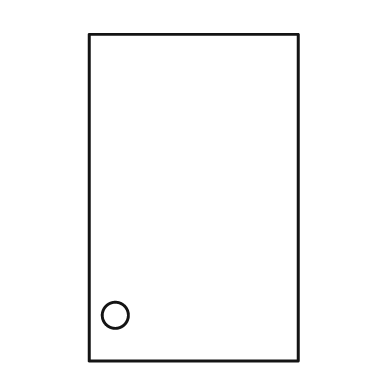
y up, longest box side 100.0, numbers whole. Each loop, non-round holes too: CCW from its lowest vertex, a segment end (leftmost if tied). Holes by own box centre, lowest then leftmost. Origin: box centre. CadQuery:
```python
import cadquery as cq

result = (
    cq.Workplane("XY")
    .moveTo(-32.0, -50.0)
    .lineTo(32.0, -50.0)
    .lineTo(32.0, 50.0)
    .lineTo(-32.0, 50.0)
    .close()
    .moveTo(-24.0, -36.0)
    .circle(4.0)
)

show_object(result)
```